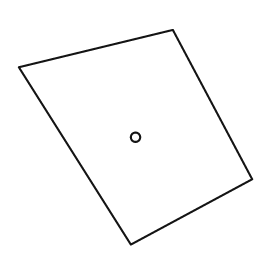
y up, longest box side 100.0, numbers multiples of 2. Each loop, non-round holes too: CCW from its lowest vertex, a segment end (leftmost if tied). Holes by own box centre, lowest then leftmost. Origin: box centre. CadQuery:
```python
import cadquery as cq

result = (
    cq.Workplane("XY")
    .moveTo(-2.0, -46.0)
    .lineTo(50.0, -18.0)
    .lineTo(16.0, 46.0)
    .lineTo(-50.0, 30.0)
    .close()
    .moveTo(0.0, 0.0)
    .circle(2.0)
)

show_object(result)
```